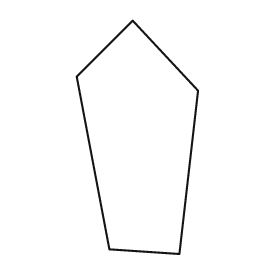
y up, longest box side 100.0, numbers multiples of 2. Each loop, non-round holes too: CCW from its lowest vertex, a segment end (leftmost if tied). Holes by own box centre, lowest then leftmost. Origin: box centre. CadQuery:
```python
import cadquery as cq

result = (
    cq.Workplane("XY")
    .moveTo(18.0, -50.0)
    .lineTo(26.0, 20.0)
    .lineTo(-2.0, 50.0)
    .lineTo(-26.0, 26.0)
    .lineTo(-12.0, -48.0)
    .close()
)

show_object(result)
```